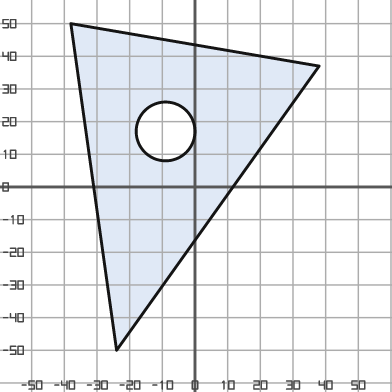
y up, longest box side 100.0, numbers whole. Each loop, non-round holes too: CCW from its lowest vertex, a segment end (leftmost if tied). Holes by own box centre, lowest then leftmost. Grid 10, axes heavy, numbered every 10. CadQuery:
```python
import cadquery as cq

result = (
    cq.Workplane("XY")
    .moveTo(-24.0, -50.0)
    .lineTo(38.0, 37.0)
    .lineTo(-38.0, 50.0)
    .close()
    .moveTo(-9.0, 17.0)
    .circle(9.0)
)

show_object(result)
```